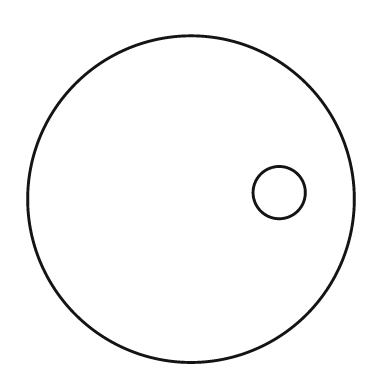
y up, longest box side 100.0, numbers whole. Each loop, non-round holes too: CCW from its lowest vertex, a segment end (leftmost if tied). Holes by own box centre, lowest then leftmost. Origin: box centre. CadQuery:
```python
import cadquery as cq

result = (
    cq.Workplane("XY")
    .moveTo(0.0, 0.0)
    .circle(50.0)
    .moveTo(27.0, 2.0)
    .circle(8.0)
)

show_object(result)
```